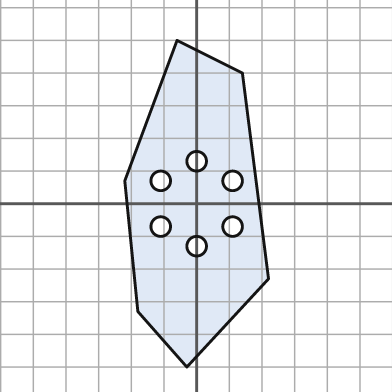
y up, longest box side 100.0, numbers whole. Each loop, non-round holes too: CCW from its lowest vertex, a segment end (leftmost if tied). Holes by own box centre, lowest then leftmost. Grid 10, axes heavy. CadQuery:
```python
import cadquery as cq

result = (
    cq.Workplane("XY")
    .moveTo(-3.0, -50.0)
    .lineTo(22.0, -23.0)
    .lineTo(14.0, 40.0)
    .lineTo(-6.0, 50.0)
    .lineTo(-22.0, 7.0)
    .lineTo(-18.0, -33.0)
    .close()
    .moveTo(0.0, -13.0)
    .circle(3.0)
    .moveTo(-11.0, -7.0)
    .circle(3.0)
    .moveTo(11.0, -7.0)
    .circle(3.0)
    .moveTo(-11.0, 7.0)
    .circle(3.0)
    .moveTo(11.0, 7.0)
    .circle(3.0)
    .moveTo(0.0, 13.0)
    .circle(3.0)
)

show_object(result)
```